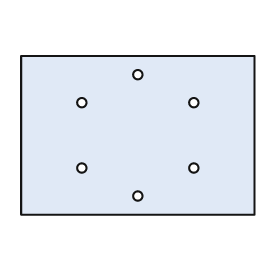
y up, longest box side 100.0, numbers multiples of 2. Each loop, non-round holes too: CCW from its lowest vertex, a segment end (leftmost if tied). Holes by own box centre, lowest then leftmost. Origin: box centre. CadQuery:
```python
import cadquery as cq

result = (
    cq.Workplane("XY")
    .moveTo(-50.0, -34.0)
    .lineTo(50.0, -34.0)
    .lineTo(50.0, 34.0)
    .lineTo(-50.0, 34.0)
    .close()
    .moveTo(0.0, -26.0)
    .circle(2.0)
    .moveTo(-24.0, -14.0)
    .circle(2.0)
    .moveTo(24.0, -14.0)
    .circle(2.0)
    .moveTo(-24.0, 14.0)
    .circle(2.0)
    .moveTo(24.0, 14.0)
    .circle(2.0)
    .moveTo(0.0, 26.0)
    .circle(2.0)
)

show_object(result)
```